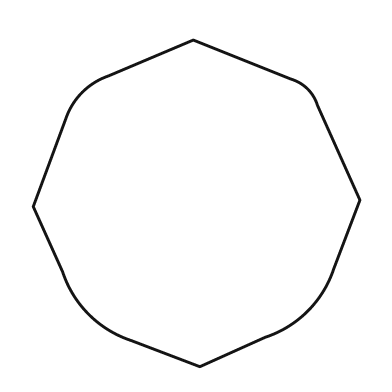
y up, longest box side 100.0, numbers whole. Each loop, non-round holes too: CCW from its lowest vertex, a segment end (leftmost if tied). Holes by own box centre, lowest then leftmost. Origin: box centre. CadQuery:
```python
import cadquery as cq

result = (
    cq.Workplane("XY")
    .moveTo(1.0, -50.0)
    .lineTo(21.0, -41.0)
    .threePointArc((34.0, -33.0), (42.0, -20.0))
    .lineTo(50.0, 1.0)
    .lineTo(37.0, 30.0)
    .threePointArc((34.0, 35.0), (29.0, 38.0))
    .lineTo(-1.0, 50.0)
    .lineTo(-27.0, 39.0)
    .threePointArc((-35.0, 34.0), (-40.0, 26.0))
    .lineTo(-50.0, -1.0)
    .lineTo(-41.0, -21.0)
    .threePointArc((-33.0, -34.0), (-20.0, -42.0))
    .close()
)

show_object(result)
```